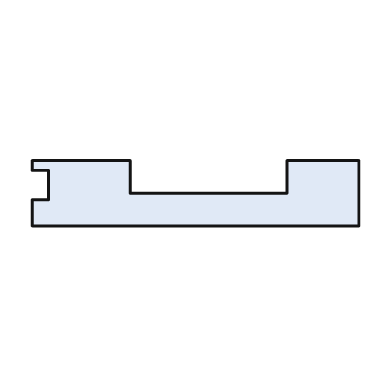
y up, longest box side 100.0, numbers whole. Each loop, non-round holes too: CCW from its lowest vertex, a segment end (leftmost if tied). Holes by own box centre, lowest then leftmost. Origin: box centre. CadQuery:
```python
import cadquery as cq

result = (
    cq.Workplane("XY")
    .moveTo(-50.0, -10.0)
    .lineTo(50.0, -10.0)
    .lineTo(50.0, 10.0)
    .lineTo(28.0, 10.0)
    .lineTo(28.0, 0.0)
    .lineTo(-20.0, 0.0)
    .lineTo(-20.0, 10.0)
    .lineTo(-50.0, 10.0)
    .lineTo(-50.0, 7.0)
    .lineTo(-45.0, 7.0)
    .lineTo(-45.0, -2.0)
    .lineTo(-50.0, -2.0)
    .close()
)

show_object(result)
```